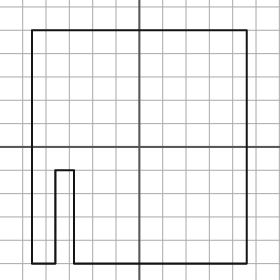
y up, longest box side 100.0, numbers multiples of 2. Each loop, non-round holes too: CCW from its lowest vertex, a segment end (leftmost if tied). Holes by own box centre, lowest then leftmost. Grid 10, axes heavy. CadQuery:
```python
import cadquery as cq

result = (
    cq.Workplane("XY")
    .moveTo(-46.0, -50.0)
    .lineTo(-36.0, -50.0)
    .lineTo(-36.0, -10.0)
    .lineTo(-28.0, -10.0)
    .lineTo(-28.0, -50.0)
    .lineTo(46.0, -50.0)
    .lineTo(46.0, 50.0)
    .lineTo(-46.0, 50.0)
    .close()
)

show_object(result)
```